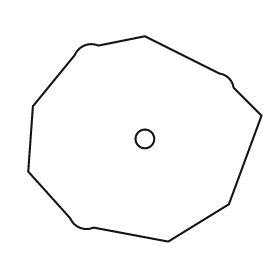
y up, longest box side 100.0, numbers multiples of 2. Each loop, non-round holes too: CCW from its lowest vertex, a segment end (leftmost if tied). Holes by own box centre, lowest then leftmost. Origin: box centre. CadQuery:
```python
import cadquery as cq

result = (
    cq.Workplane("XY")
    .moveTo(10.0, -44.0)
    .lineTo(36.0, -28.0)
    .lineTo(50.0, 10.0)
    .lineTo(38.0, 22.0)
    .threePointArc((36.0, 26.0), (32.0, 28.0))
    .lineTo(0.0, 44.0)
    .lineTo(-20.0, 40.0)
    .threePointArc((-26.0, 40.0), (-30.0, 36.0))
    .lineTo(-48.0, 14.0)
    .lineTo(-50.0, -14.0)
    .lineTo(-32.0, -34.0)
    .threePointArc((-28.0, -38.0), (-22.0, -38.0))
    .close()
    .moveTo(0.0, 0.0)
    .circle(4.0)
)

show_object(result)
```